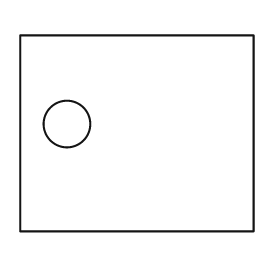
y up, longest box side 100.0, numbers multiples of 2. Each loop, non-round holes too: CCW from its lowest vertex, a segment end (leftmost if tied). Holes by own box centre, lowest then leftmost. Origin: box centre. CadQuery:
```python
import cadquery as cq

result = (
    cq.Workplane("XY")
    .moveTo(-50.0, -42.0)
    .lineTo(50.0, -42.0)
    .lineTo(50.0, 42.0)
    .lineTo(-50.0, 42.0)
    .close()
    .moveTo(-30.0, 4.0)
    .circle(10.0)
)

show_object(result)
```